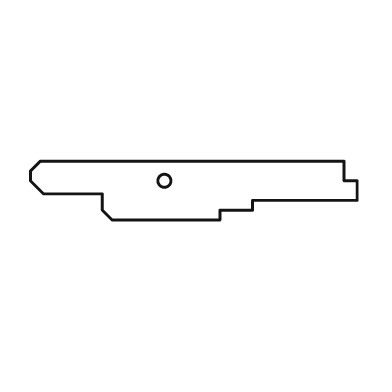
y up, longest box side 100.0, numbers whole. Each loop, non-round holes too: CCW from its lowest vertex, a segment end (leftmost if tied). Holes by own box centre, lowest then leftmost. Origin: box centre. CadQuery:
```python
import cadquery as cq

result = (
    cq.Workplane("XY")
    .moveTo(-25.0, -9.0)
    .lineTo(8.0, -9.0)
    .lineTo(8.0, -6.0)
    .lineTo(18.0, -6.0)
    .lineTo(18.0, -3.0)
    .lineTo(50.0, -3.0)
    .lineTo(50.0, 3.0)
    .lineTo(46.0, 3.0)
    .lineTo(46.0, 9.0)
    .lineTo(-47.0, 9.0)
    .lineTo(-50.0, 6.0)
    .lineTo(-50.0, 3.0)
    .lineTo(-46.0, -1.0)
    .lineTo(-28.0, -1.0)
    .lineTo(-28.0, -6.0)
    .close()
    .moveTo(-9.0, 3.0)
    .circle(2.0)
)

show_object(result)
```